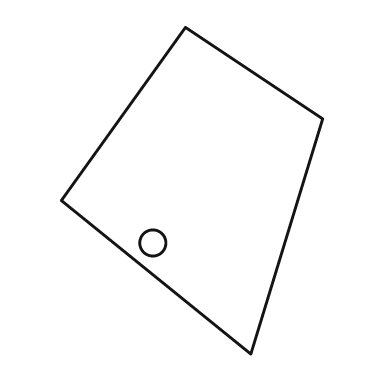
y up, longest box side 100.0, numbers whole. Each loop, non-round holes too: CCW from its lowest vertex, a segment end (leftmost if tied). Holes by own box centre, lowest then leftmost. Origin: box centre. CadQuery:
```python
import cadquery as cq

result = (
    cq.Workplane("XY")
    .moveTo(18.0, -50.0)
    .lineTo(40.0, 22.0)
    .lineTo(-2.0, 50.0)
    .lineTo(-40.0, -3.0)
    .close()
    .moveTo(-12.0, -16.0)
    .circle(4.0)
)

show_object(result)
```